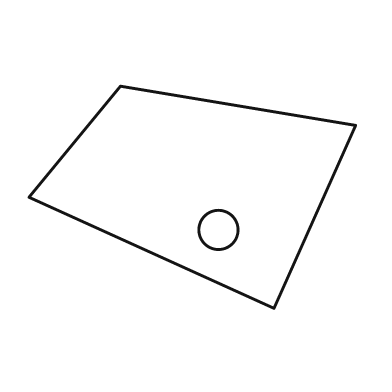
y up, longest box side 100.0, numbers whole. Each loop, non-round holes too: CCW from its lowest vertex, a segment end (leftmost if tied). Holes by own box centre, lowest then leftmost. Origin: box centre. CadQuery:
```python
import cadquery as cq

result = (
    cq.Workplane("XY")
    .moveTo(25.0, -34.0)
    .lineTo(50.0, 22.0)
    .lineTo(-22.0, 34.0)
    .lineTo(-50.0, 0.0)
    .close()
    .moveTo(8.0, -10.0)
    .circle(6.0)
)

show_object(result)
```